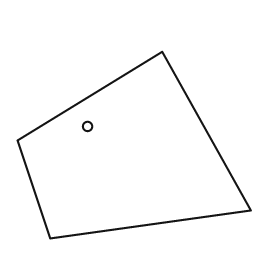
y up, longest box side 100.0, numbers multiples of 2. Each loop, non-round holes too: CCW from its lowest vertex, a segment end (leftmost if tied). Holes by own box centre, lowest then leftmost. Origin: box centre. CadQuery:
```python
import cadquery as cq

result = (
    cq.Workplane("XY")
    .moveTo(-36.0, -40.0)
    .lineTo(50.0, -28.0)
    .lineTo(12.0, 40.0)
    .lineTo(-50.0, 2.0)
    .close()
    .moveTo(-20.0, 8.0)
    .circle(2.0)
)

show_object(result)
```